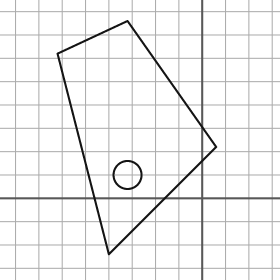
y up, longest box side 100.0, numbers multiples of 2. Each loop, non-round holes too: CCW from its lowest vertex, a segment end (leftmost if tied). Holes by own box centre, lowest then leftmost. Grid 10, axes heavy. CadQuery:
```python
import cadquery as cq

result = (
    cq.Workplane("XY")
    .moveTo(-40.0, -24.0)
    .lineTo(6.0, 22.0)
    .lineTo(-32.0, 76.0)
    .lineTo(-62.0, 62.0)
    .close()
    .moveTo(-32.0, 10.0)
    .circle(6.0)
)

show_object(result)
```